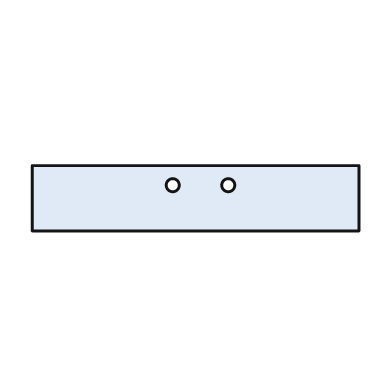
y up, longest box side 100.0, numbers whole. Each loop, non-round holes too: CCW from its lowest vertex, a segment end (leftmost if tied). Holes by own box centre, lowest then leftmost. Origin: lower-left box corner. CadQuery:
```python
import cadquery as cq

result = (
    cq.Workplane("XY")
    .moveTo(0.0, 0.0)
    .lineTo(100.0, 0.0)
    .lineTo(100.0, 20.0)
    .lineTo(0.0, 20.0)
    .close()
    .moveTo(43.0, 14.0)
    .circle(2.0)
    .moveTo(60.0, 14.0)
    .circle(2.0)
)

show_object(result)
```